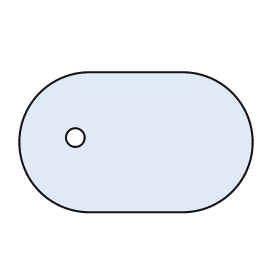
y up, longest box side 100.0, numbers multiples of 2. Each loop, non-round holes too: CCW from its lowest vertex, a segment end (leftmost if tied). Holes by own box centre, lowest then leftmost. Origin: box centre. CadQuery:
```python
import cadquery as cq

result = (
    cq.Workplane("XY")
    .moveTo(-20.0, -30.0)
    .lineTo(20.0, -30.0)
    .threePointArc((50.0, 0.0), (20.0, 30.0))
    .lineTo(-20.0, 30.0)
    .threePointArc((-50.0, 0.0), (-20.0, -30.0))
    .close()
    .moveTo(-26.0, 2.0)
    .circle(4.0)
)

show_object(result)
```